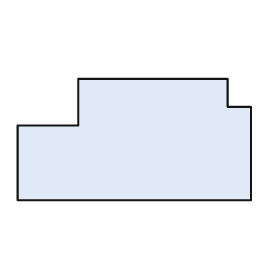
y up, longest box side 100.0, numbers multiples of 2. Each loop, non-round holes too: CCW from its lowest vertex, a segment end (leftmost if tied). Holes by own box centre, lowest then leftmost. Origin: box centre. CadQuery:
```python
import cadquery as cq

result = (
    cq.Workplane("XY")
    .moveTo(-50.0, -26.0)
    .lineTo(50.0, -26.0)
    .lineTo(50.0, 14.0)
    .lineTo(40.0, 14.0)
    .lineTo(40.0, 26.0)
    .lineTo(-24.0, 26.0)
    .lineTo(-24.0, 6.0)
    .lineTo(-50.0, 6.0)
    .close()
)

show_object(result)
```